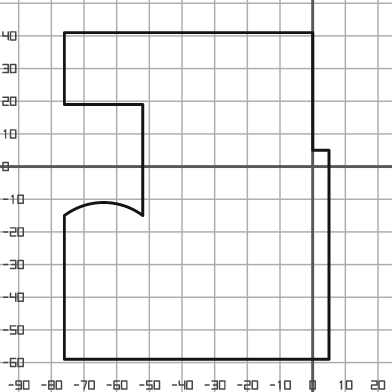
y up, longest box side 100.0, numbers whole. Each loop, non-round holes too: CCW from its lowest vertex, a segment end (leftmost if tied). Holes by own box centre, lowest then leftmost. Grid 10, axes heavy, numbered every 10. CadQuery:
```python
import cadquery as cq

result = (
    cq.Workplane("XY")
    .moveTo(-76.0, -59.0)
    .lineTo(5.0, -59.0)
    .lineTo(5.0, 5.0)
    .lineTo(0.0, 5.0)
    .lineTo(0.0, 41.0)
    .lineTo(-76.0, 41.0)
    .lineTo(-76.0, 19.0)
    .lineTo(-52.0, 19.0)
    .lineTo(-52.0, -15.0)
    .threePointArc((-64.0, -11.0), (-76.0, -15.0))
    .close()
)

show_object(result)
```